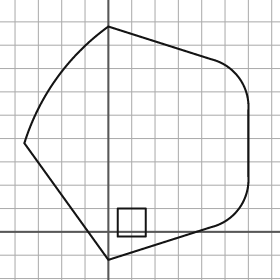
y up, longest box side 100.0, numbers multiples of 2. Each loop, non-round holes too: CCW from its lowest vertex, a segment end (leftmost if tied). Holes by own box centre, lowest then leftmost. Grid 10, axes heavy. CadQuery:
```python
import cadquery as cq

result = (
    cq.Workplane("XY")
    .moveTo(0.0, -12.0)
    .lineTo(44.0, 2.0)
    .threePointArc((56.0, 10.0), (60.0, 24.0))
    .lineTo(60.0, 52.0)
    .threePointArc((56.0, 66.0), (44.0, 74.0))
    .lineTo(0.0, 88.0)
    .threePointArc((-22.0, 66.0), (-36.0, 38.0))
    .close()
    .moveTo(4.0, -2.0)
    .lineTo(16.0, -2.0)
    .lineTo(16.0, 10.0)
    .lineTo(4.0, 10.0)
    .close()
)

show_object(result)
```